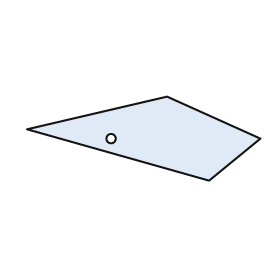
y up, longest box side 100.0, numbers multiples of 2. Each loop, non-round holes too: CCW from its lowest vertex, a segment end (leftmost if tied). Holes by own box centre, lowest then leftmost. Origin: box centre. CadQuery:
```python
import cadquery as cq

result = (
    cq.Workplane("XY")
    .moveTo(28.0, -18.0)
    .lineTo(50.0, 0.0)
    .lineTo(10.0, 18.0)
    .lineTo(-50.0, 4.0)
    .close()
    .moveTo(-14.0, 0.0)
    .circle(2.0)
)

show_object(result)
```